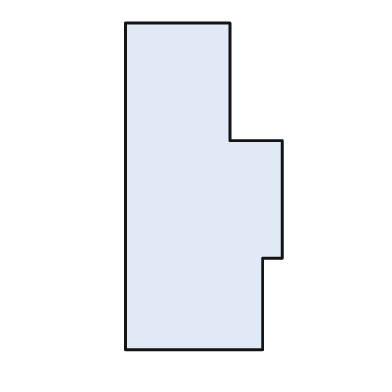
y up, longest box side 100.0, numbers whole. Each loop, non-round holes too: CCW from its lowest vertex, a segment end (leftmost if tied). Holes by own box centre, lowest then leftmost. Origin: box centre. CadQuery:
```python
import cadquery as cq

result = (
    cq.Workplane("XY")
    .moveTo(-24.0, -50.0)
    .lineTo(18.0, -50.0)
    .lineTo(18.0, -22.0)
    .lineTo(24.0, -22.0)
    .lineTo(24.0, 14.0)
    .lineTo(8.0, 14.0)
    .lineTo(8.0, 50.0)
    .lineTo(-24.0, 50.0)
    .close()
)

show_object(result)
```